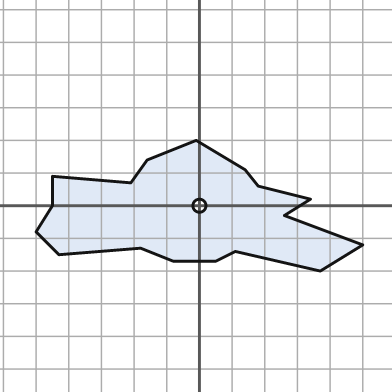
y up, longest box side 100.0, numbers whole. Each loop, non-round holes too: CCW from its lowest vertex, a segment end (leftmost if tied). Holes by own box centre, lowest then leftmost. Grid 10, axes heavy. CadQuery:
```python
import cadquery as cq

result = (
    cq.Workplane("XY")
    .moveTo(37.0, -20.0)
    .lineTo(50.0, -12.0)
    .lineTo(26.0, -3.0)
    .lineTo(34.0, 2.0)
    .lineTo(18.0, 6.0)
    .lineTo(14.0, 11.0)
    .lineTo(-1.0, 20.0)
    .lineTo(-16.0, 14.0)
    .lineTo(-21.0, 7.0)
    .lineTo(-45.0, 9.0)
    .lineTo(-45.0, 0.0)
    .lineTo(-50.0, -8.0)
    .lineTo(-43.0, -15.0)
    .lineTo(-18.0, -13.0)
    .lineTo(-8.0, -17.0)
    .lineTo(5.0, -17.0)
    .lineTo(11.0, -14.0)
    .close()
    .moveTo(0.0, 0.0)
    .circle(2.0)
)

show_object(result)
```